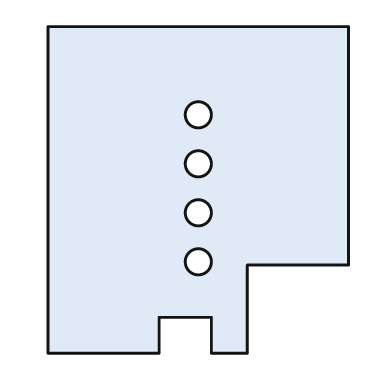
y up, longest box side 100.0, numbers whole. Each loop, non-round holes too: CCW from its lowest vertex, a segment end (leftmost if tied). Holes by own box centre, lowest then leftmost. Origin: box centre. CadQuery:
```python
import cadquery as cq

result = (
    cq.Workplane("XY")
    .moveTo(-46.0, -50.0)
    .lineTo(-12.0, -50.0)
    .lineTo(-12.0, -39.0)
    .lineTo(4.0, -39.0)
    .lineTo(4.0, -50.0)
    .lineTo(15.0, -50.0)
    .lineTo(15.0, -23.0)
    .lineTo(46.0, -23.0)
    .lineTo(46.0, 50.0)
    .lineTo(-46.0, 50.0)
    .close()
    .moveTo(0.0, -22.0)
    .circle(4.0)
    .moveTo(0.0, -7.0)
    .circle(4.0)
    .moveTo(0.0, 8.0)
    .circle(4.0)
    .moveTo(0.0, 23.0)
    .circle(4.0)
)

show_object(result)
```